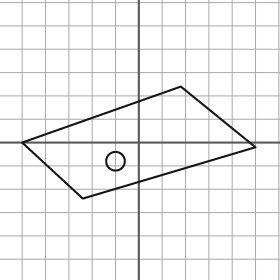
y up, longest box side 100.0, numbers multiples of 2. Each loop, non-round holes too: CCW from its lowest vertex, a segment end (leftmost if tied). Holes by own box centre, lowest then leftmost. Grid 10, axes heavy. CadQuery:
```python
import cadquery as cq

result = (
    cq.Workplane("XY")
    .moveTo(-24.0, -24.0)
    .lineTo(50.0, -2.0)
    .lineTo(18.0, 24.0)
    .lineTo(-50.0, 0.0)
    .close()
    .moveTo(-10.0, -8.0)
    .circle(4.0)
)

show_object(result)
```